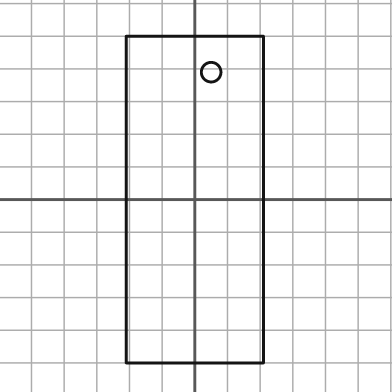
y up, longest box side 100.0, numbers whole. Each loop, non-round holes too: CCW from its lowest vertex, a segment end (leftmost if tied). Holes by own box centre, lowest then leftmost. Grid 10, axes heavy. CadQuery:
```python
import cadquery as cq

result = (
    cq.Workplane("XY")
    .moveTo(-21.0, -50.0)
    .lineTo(21.0, -50.0)
    .lineTo(21.0, 50.0)
    .lineTo(-21.0, 50.0)
    .close()
    .moveTo(5.0, 39.0)
    .circle(3.0)
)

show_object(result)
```